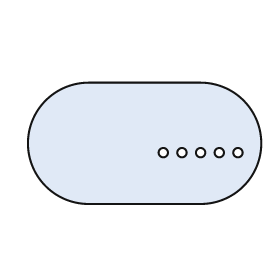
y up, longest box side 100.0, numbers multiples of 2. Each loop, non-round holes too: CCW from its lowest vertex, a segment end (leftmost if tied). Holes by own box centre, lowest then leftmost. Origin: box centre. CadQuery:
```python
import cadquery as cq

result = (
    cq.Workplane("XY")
    .moveTo(-24.0, -26.0)
    .lineTo(24.0, -26.0)
    .threePointArc((50.0, 0.0), (24.0, 26.0))
    .lineTo(-24.0, 26.0)
    .threePointArc((-50.0, 0.0), (-24.0, -26.0))
    .close()
    .moveTo(8.0, -4.0)
    .circle(2.0)
    .moveTo(16.0, -4.0)
    .circle(2.0)
    .moveTo(24.0, -4.0)
    .circle(2.0)
    .moveTo(32.0, -4.0)
    .circle(2.0)
    .moveTo(40.0, -4.0)
    .circle(2.0)
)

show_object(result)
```